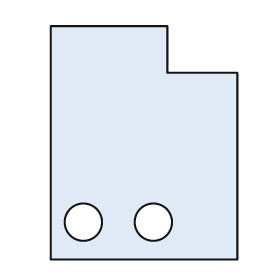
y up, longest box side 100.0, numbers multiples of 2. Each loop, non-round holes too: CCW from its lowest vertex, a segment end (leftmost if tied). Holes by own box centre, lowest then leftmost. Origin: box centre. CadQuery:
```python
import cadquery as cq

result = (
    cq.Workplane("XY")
    .moveTo(-40.0, -50.0)
    .lineTo(40.0, -50.0)
    .lineTo(40.0, 30.0)
    .lineTo(10.0, 30.0)
    .lineTo(10.0, 50.0)
    .lineTo(-40.0, 50.0)
    .close()
    .moveTo(-26.0, -34.0)
    .circle(8.0)
    .moveTo(4.0, -34.0)
    .circle(8.0)
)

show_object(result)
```